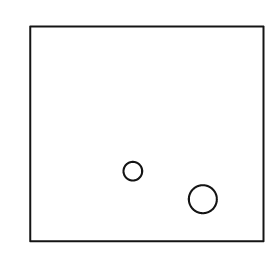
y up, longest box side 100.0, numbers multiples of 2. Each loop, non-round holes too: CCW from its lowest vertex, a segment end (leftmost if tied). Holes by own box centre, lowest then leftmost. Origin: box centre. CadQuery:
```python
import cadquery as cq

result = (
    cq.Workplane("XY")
    .moveTo(-50.0, -46.0)
    .lineTo(50.0, -46.0)
    .lineTo(50.0, 46.0)
    .lineTo(-50.0, 46.0)
    .close()
    .moveTo(24.0, -28.0)
    .circle(6.0)
    .moveTo(-6.0, -16.0)
    .circle(4.0)
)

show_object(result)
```